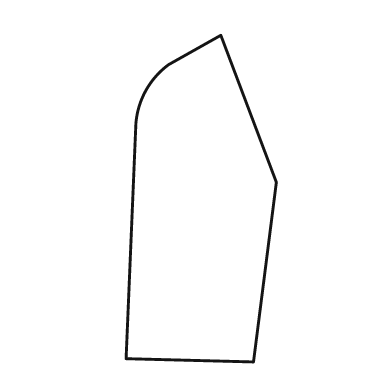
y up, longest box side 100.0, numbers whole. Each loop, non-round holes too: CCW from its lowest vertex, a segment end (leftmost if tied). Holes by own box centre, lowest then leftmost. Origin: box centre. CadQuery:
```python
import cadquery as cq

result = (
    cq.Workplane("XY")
    .moveTo(16.0, -50.0)
    .lineTo(23.0, 5.0)
    .lineTo(6.0, 50.0)
    .lineTo(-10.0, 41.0)
    .threePointArc((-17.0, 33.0), (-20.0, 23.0))
    .lineTo(-23.0, -49.0)
    .close()
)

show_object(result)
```